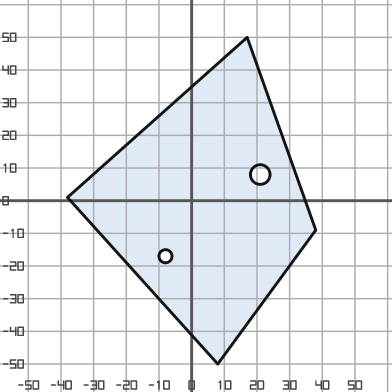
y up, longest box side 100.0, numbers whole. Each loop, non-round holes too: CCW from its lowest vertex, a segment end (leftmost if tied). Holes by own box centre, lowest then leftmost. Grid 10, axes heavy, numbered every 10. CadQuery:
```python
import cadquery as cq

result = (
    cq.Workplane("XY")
    .moveTo(8.0, -50.0)
    .lineTo(38.0, -9.0)
    .lineTo(17.0, 50.0)
    .lineTo(-38.0, 1.0)
    .close()
    .moveTo(-8.0, -17.0)
    .circle(2.0)
    .moveTo(21.0, 8.0)
    .circle(3.0)
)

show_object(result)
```